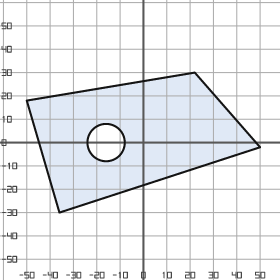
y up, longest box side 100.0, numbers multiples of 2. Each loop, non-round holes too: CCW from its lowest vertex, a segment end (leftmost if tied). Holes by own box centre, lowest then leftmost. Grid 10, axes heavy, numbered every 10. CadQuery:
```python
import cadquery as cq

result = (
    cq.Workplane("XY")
    .moveTo(-36.0, -30.0)
    .lineTo(50.0, -2.0)
    .lineTo(22.0, 30.0)
    .lineTo(-50.0, 18.0)
    .close()
    .moveTo(-16.0, 0.0)
    .circle(8.0)
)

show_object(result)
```